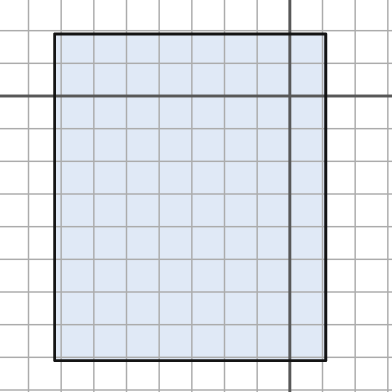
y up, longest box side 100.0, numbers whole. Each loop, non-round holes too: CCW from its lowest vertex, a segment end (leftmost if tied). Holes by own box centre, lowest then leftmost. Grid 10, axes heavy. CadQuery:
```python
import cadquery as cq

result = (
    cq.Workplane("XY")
    .moveTo(-72.0, -81.0)
    .lineTo(11.0, -81.0)
    .lineTo(11.0, 19.0)
    .lineTo(-72.0, 19.0)
    .close()
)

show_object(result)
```